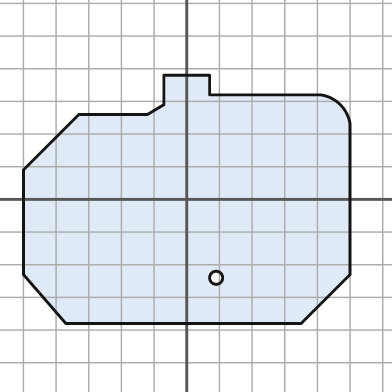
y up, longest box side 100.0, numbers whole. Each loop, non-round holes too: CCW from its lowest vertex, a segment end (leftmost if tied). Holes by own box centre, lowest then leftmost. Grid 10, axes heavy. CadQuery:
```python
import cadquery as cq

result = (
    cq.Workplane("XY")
    .moveTo(-37.0, -38.0)
    .lineTo(35.0, -38.0)
    .lineTo(50.0, -23.0)
    .lineTo(50.0, 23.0)
    .threePointArc((47.0, 29.0), (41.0, 32.0))
    .lineTo(7.0, 32.0)
    .lineTo(7.0, 38.0)
    .lineTo(-7.0, 38.0)
    .lineTo(-7.0, 29.0)
    .lineTo(-12.0, 26.0)
    .lineTo(-33.0, 26.0)
    .lineTo(-50.0, 9.0)
    .lineTo(-50.0, -23.0)
    .close()
    .moveTo(9.0, -24.0)
    .circle(2.0)
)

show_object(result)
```